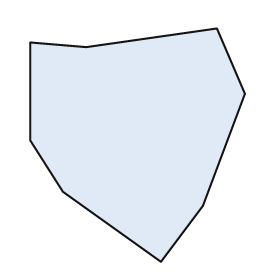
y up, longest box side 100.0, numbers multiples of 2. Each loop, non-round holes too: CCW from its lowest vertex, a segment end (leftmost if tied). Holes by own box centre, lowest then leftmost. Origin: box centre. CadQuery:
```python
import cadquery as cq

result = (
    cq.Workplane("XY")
    .moveTo(10.0, -50.0)
    .lineTo(28.0, -26.0)
    .lineTo(46.0, 22.0)
    .lineTo(34.0, 50.0)
    .lineTo(-22.0, 42.0)
    .lineTo(-46.0, 44.0)
    .lineTo(-46.0, 2.0)
    .lineTo(-32.0, -20.0)
    .close()
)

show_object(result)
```